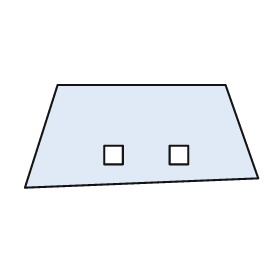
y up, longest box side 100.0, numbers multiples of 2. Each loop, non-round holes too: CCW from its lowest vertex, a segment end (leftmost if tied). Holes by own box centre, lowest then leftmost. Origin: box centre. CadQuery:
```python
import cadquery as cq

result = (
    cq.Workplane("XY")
    .moveTo(-50.0, -22.0)
    .lineTo(50.0, -18.0)
    .lineTo(36.0, 22.0)
    .lineTo(-36.0, 22.0)
    .close()
    .moveTo(-16.0, -12.0)
    .lineTo(-8.0, -12.0)
    .lineTo(-8.0, -4.0)
    .lineTo(-16.0, -4.0)
    .close()
    .moveTo(12.0, -12.0)
    .lineTo(20.0, -12.0)
    .lineTo(20.0, -4.0)
    .lineTo(12.0, -4.0)
    .close()
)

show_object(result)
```